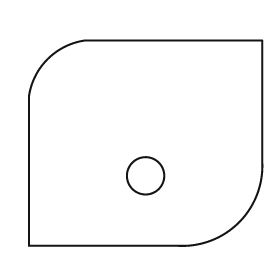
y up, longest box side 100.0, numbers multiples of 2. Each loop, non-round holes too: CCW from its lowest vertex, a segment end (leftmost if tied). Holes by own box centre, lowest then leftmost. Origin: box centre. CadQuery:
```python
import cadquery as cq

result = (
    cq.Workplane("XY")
    .moveTo(-50.0, -44.0)
    .lineTo(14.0, -44.0)
    .threePointArc((40.0, -34.0), (50.0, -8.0))
    .lineTo(50.0, 44.0)
    .lineTo(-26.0, 44.0)
    .threePointArc((-42.0, 36.0), (-50.0, 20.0))
    .close()
    .moveTo(0.0, -14.0)
    .circle(8.0)
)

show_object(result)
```